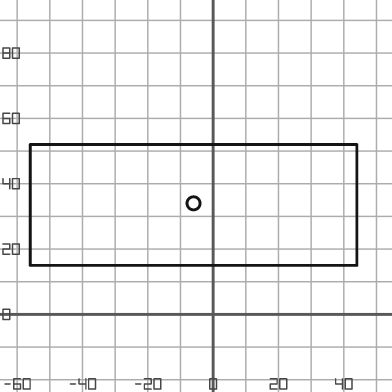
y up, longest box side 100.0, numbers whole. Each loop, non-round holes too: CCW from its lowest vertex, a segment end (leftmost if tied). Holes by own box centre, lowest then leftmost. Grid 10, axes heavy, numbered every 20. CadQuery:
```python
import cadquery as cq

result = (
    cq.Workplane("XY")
    .moveTo(-56.0, 15.0)
    .lineTo(44.0, 15.0)
    .lineTo(44.0, 52.0)
    .lineTo(-56.0, 52.0)
    .close()
    .moveTo(-6.0, 34.0)
    .circle(2.0)
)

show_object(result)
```